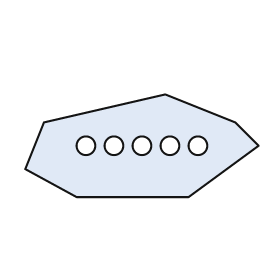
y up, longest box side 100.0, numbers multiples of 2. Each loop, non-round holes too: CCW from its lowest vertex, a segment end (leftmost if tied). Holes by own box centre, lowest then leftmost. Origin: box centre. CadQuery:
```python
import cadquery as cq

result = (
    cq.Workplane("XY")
    .moveTo(-28.0, -22.0)
    .lineTo(20.0, -22.0)
    .lineTo(50.0, 0.0)
    .lineTo(40.0, 10.0)
    .lineTo(10.0, 22.0)
    .lineTo(-42.0, 10.0)
    .lineTo(-50.0, -10.0)
    .close()
    .moveTo(-24.0, 0.0)
    .circle(4.0)
    .moveTo(-12.0, 0.0)
    .circle(4.0)
    .moveTo(0.0, 0.0)
    .circle(4.0)
    .moveTo(12.0, 0.0)
    .circle(4.0)
    .moveTo(24.0, 0.0)
    .circle(4.0)
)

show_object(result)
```